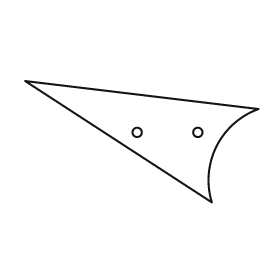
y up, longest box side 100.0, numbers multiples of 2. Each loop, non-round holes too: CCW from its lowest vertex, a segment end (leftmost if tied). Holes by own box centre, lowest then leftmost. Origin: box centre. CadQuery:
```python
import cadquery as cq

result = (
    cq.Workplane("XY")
    .moveTo(30.0, -26.0)
    .threePointArc((32.0, -2.0), (50.0, 14.0))
    .lineTo(-50.0, 26.0)
    .close()
    .moveTo(-2.0, 4.0)
    .circle(2.0)
    .moveTo(24.0, 4.0)
    .circle(2.0)
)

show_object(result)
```